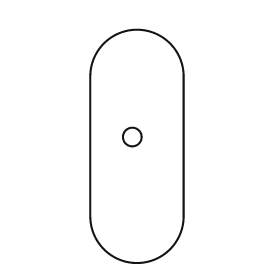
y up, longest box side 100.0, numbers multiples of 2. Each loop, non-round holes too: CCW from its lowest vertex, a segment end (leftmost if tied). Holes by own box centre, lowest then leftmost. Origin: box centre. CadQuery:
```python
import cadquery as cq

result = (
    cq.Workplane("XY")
    .moveTo(-20.0, -30.0)
    .threePointArc((0.0, -50.0), (20.0, -30.0))
    .lineTo(20.0, 30.0)
    .threePointArc((0.0, 50.0), (-20.0, 30.0))
    .close()
    .moveTo(-2.0, 4.0)
    .circle(4.0)
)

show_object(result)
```